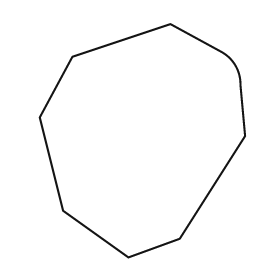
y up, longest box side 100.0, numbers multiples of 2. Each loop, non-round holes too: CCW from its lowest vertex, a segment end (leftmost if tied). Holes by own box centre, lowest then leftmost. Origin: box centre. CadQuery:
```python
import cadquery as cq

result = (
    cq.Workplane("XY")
    .moveTo(-6.0, -50.0)
    .lineTo(16.0, -42.0)
    .lineTo(44.0, 2.0)
    .lineTo(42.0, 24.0)
    .threePointArc((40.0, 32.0), (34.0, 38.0))
    .lineTo(12.0, 50.0)
    .lineTo(-30.0, 36.0)
    .lineTo(-44.0, 10.0)
    .lineTo(-34.0, -30.0)
    .close()
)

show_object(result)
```